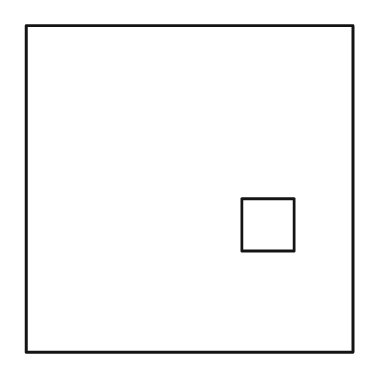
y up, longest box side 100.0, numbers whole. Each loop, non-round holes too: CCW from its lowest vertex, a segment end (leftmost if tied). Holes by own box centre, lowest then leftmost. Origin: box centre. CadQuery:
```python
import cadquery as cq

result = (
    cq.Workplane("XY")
    .moveTo(-50.0, -50.0)
    .lineTo(50.0, -50.0)
    .lineTo(50.0, 50.0)
    .lineTo(-50.0, 50.0)
    .close()
    .moveTo(16.0, -19.0)
    .lineTo(32.0, -19.0)
    .lineTo(32.0, -3.0)
    .lineTo(16.0, -3.0)
    .close()
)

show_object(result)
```